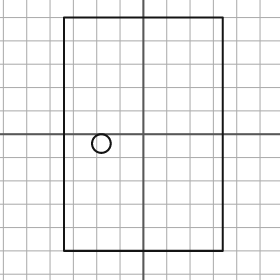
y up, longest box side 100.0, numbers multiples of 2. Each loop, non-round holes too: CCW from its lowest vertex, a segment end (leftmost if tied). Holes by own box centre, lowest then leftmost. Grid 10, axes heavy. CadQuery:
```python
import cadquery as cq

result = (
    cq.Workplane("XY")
    .moveTo(-34.0, -50.0)
    .lineTo(34.0, -50.0)
    .lineTo(34.0, 50.0)
    .lineTo(-34.0, 50.0)
    .close()
    .moveTo(-18.0, -4.0)
    .circle(4.0)
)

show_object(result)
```